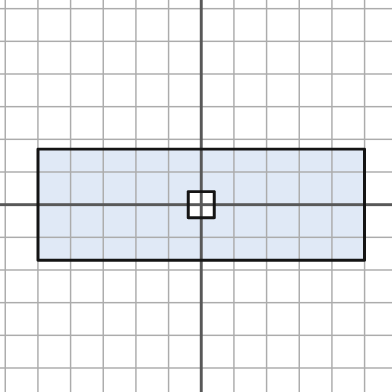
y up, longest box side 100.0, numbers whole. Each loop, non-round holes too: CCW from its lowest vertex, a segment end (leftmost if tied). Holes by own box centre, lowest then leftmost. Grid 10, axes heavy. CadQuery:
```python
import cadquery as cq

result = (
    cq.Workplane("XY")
    .moveTo(-50.0, -17.0)
    .lineTo(50.0, -17.0)
    .lineTo(50.0, 17.0)
    .lineTo(-50.0, 17.0)
    .close()
    .moveTo(-4.0, -4.0)
    .lineTo(4.0, -4.0)
    .lineTo(4.0, 4.0)
    .lineTo(-4.0, 4.0)
    .close()
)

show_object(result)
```